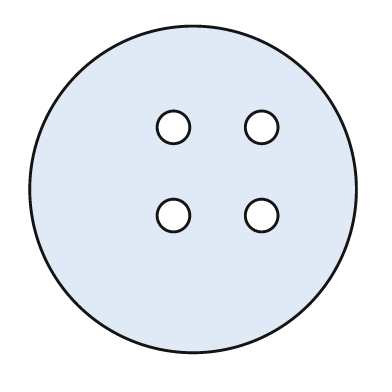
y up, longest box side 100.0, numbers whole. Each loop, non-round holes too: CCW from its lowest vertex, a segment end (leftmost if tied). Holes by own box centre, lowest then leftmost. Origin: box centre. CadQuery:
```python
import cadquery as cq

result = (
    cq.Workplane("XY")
    .moveTo(0.0, 0.0)
    .circle(50.0)
    .moveTo(-6.0, -8.0)
    .circle(5.0)
    .moveTo(21.0, -8.0)
    .circle(5.0)
    .moveTo(-6.0, 19.0)
    .circle(5.0)
    .moveTo(21.0, 19.0)
    .circle(5.0)
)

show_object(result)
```